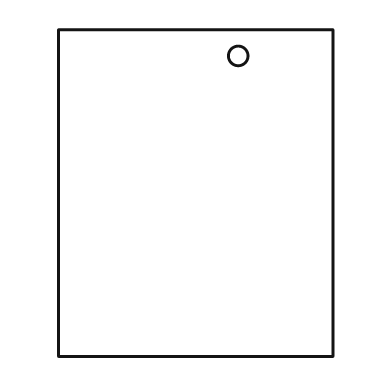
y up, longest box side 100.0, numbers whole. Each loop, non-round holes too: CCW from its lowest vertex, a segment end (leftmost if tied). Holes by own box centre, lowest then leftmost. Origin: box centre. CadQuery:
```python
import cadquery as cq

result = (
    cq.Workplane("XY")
    .moveTo(-42.0, -50.0)
    .lineTo(42.0, -50.0)
    .lineTo(42.0, 50.0)
    .lineTo(-42.0, 50.0)
    .close()
    .moveTo(13.0, 42.0)
    .circle(3.0)
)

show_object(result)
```